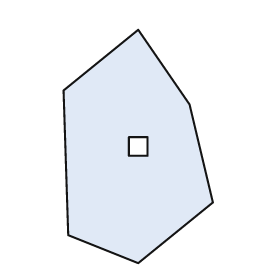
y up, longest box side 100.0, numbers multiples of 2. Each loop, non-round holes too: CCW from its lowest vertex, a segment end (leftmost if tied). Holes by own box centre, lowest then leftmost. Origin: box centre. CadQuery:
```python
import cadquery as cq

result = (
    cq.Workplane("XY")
    .moveTo(0.0, -50.0)
    .lineTo(32.0, -24.0)
    .lineTo(22.0, 18.0)
    .lineTo(0.0, 50.0)
    .lineTo(-32.0, 24.0)
    .lineTo(-30.0, -38.0)
    .close()
    .moveTo(-4.0, -4.0)
    .lineTo(4.0, -4.0)
    .lineTo(4.0, 4.0)
    .lineTo(-4.0, 4.0)
    .close()
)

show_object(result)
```